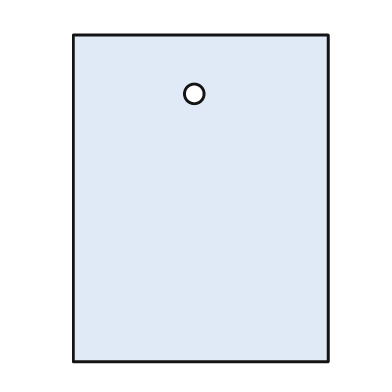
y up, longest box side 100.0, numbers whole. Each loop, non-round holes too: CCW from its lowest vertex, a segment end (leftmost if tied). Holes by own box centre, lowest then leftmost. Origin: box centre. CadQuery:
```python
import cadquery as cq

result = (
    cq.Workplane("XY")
    .moveTo(-39.0, -50.0)
    .lineTo(39.0, -50.0)
    .lineTo(39.0, 50.0)
    .lineTo(-39.0, 50.0)
    .close()
    .moveTo(-2.0, 32.0)
    .circle(3.0)
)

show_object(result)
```